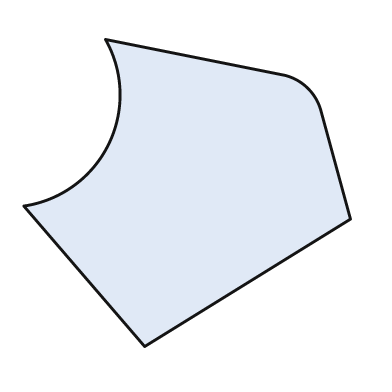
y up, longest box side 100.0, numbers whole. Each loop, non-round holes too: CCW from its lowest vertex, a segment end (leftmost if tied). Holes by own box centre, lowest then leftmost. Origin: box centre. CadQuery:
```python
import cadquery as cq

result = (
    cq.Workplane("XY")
    .moveTo(-13.0, -47.0)
    .lineTo(50.0, -8.0)
    .lineTo(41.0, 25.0)
    .threePointArc((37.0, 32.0), (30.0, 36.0))
    .lineTo(-25.0, 47.0)
    .threePointArc((-24.0, 15.0), (-50.0, -4.0))
    .close()
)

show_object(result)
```